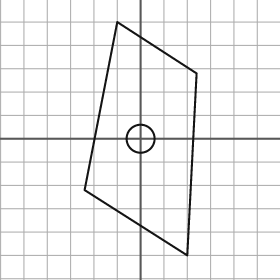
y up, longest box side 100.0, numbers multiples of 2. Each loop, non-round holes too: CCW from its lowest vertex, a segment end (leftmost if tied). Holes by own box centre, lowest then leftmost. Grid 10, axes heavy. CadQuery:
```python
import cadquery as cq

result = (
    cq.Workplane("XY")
    .moveTo(20.0, -50.0)
    .lineTo(24.0, 28.0)
    .lineTo(-10.0, 50.0)
    .lineTo(-24.0, -22.0)
    .close()
    .moveTo(0.0, 0.0)
    .circle(6.0)
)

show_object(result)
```